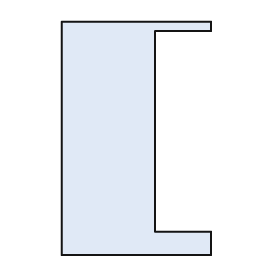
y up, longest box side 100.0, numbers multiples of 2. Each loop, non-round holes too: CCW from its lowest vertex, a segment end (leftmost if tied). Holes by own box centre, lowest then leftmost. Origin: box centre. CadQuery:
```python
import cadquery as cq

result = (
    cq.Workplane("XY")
    .moveTo(-32.0, -50.0)
    .lineTo(32.0, -50.0)
    .lineTo(32.0, -40.0)
    .lineTo(8.0, -40.0)
    .lineTo(8.0, 46.0)
    .lineTo(32.0, 46.0)
    .lineTo(32.0, 50.0)
    .lineTo(-32.0, 50.0)
    .close()
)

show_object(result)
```